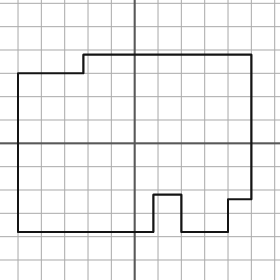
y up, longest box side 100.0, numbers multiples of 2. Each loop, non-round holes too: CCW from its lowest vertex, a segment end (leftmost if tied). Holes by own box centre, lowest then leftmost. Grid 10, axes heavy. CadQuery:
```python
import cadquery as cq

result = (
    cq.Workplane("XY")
    .moveTo(-50.0, -38.0)
    .lineTo(8.0, -38.0)
    .lineTo(8.0, -22.0)
    .lineTo(20.0, -22.0)
    .lineTo(20.0, -38.0)
    .lineTo(40.0, -38.0)
    .lineTo(40.0, -24.0)
    .lineTo(50.0, -24.0)
    .lineTo(50.0, 38.0)
    .lineTo(-22.0, 38.0)
    .lineTo(-22.0, 30.0)
    .lineTo(-50.0, 30.0)
    .close()
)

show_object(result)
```